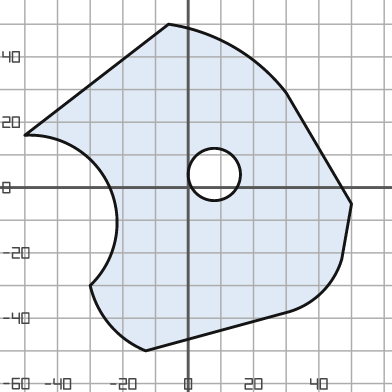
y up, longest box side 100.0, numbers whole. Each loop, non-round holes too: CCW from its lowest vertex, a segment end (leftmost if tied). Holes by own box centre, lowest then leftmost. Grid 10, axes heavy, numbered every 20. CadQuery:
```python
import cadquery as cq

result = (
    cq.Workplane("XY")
    .moveTo(-13.0, -50.0)
    .lineTo(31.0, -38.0)
    .threePointArc((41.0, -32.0), (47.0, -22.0))
    .lineTo(50.0, -5.0)
    .lineTo(30.0, 29.0)
    .threePointArc((14.0, 43.0), (-6.0, 50.0))
    .lineTo(-50.0, 16.0)
    .threePointArc((-24.0, 0.0), (-30.0, -30.0))
    .threePointArc((-24.0, -42.0), (-13.0, -50.0))
    .close()
    .moveTo(8.0, 4.0)
    .circle(8.0)
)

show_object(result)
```